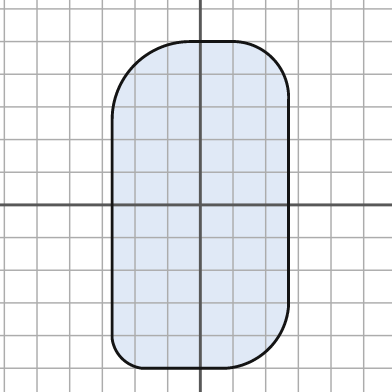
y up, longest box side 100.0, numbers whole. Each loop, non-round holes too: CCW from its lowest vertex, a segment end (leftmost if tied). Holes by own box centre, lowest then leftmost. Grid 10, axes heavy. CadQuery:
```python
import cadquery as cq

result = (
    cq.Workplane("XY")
    .moveTo(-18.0, -50.0)
    .lineTo(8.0, -50.0)
    .threePointArc((21.0, -44.0), (27.0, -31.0))
    .lineTo(27.0, 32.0)
    .threePointArc((22.0, 45.0), (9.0, 50.0))
    .lineTo(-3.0, 50.0)
    .threePointArc((-20.0, 43.0), (-27.0, 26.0))
    .lineTo(-27.0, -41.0)
    .threePointArc((-24.0, -47.0), (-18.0, -50.0))
    .close()
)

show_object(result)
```